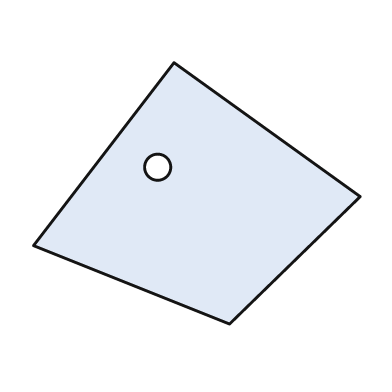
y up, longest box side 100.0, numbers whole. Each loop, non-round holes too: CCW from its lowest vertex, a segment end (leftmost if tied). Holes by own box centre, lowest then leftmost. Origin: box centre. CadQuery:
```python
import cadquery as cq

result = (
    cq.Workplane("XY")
    .moveTo(10.0, -40.0)
    .lineTo(50.0, -1.0)
    .lineTo(-7.0, 40.0)
    .lineTo(-50.0, -16.0)
    .close()
    .moveTo(-12.0, 8.0)
    .circle(4.0)
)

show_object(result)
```